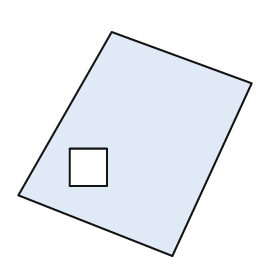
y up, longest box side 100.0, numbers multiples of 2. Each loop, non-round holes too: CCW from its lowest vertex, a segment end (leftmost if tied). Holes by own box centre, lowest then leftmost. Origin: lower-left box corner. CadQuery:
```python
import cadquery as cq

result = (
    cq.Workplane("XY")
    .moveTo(66.0, 0.0)
    .lineTo(100.0, 74.0)
    .lineTo(40.0, 96.0)
    .lineTo(0.0, 26.0)
    .close()
    .moveTo(22.0, 30.0)
    .lineTo(38.0, 30.0)
    .lineTo(38.0, 46.0)
    .lineTo(22.0, 46.0)
    .close()
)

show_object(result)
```